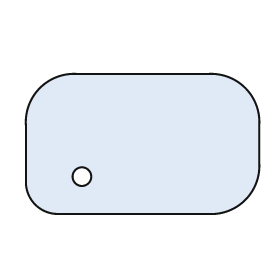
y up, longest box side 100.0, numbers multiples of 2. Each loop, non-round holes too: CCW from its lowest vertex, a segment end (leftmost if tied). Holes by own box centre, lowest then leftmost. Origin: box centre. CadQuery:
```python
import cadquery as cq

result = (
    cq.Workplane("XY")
    .moveTo(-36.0, -30.0)
    .lineTo(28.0, -30.0)
    .threePointArc((44.0, -24.0), (50.0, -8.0))
    .lineTo(50.0, 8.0)
    .threePointArc((44.0, 24.0), (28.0, 30.0))
    .lineTo(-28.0, 30.0)
    .threePointArc((-44.0, 24.0), (-50.0, 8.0))
    .lineTo(-50.0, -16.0)
    .threePointArc((-46.0, -26.0), (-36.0, -30.0))
    .close()
    .moveTo(-26.0, -14.0)
    .circle(4.0)
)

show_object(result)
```